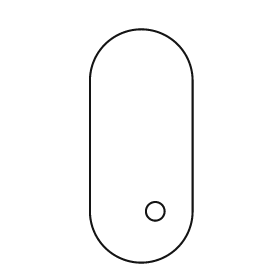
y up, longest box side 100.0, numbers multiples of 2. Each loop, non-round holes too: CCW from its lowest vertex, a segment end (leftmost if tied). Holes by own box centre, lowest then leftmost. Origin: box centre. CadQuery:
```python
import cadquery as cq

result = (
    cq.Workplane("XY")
    .moveTo(-22.0, -28.0)
    .threePointArc((0.0, -50.0), (22.0, -28.0))
    .lineTo(22.0, 28.0)
    .threePointArc((0.0, 50.0), (-22.0, 28.0))
    .close()
    .moveTo(6.0, -28.0)
    .circle(4.0)
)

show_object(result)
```